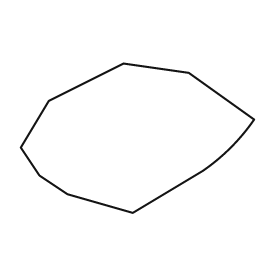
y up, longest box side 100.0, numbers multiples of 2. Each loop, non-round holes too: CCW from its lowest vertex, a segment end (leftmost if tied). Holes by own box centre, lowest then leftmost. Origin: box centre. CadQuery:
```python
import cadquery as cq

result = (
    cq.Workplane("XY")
    .moveTo(-2.0, -32.0)
    .lineTo(28.0, -14.0)
    .threePointArc((40.0, -4.0), (50.0, 8.0))
    .lineTo(22.0, 28.0)
    .lineTo(-6.0, 32.0)
    .lineTo(-38.0, 16.0)
    .lineTo(-50.0, -4.0)
    .lineTo(-42.0, -16.0)
    .lineTo(-30.0, -24.0)
    .close()
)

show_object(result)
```